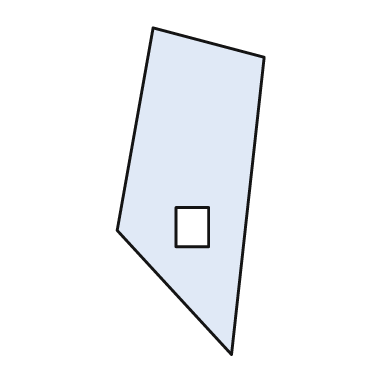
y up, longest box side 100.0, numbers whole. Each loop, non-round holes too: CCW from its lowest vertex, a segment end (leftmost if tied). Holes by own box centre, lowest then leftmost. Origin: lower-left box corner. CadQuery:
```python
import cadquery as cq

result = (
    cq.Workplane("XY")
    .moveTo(35.0, 0.0)
    .lineTo(45.0, 91.0)
    .lineTo(11.0, 100.0)
    .lineTo(0.0, 38.0)
    .close()
    .moveTo(18.0, 33.0)
    .lineTo(28.0, 33.0)
    .lineTo(28.0, 45.0)
    .lineTo(18.0, 45.0)
    .close()
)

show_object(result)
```